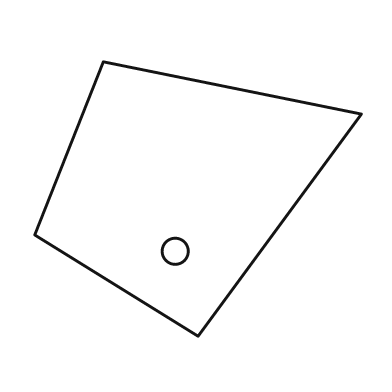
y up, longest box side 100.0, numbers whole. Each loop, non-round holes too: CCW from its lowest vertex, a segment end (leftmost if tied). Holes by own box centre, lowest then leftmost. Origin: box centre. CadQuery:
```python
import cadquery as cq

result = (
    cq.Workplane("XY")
    .moveTo(0.0, -42.0)
    .lineTo(50.0, 26.0)
    .lineTo(-29.0, 42.0)
    .lineTo(-50.0, -11.0)
    .close()
    .moveTo(-7.0, -16.0)
    .circle(4.0)
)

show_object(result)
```